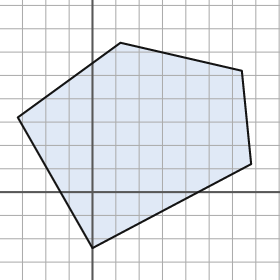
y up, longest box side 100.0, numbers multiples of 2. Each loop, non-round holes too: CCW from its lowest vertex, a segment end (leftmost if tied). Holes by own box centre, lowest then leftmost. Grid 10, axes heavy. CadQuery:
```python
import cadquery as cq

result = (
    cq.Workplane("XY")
    .moveTo(0.0, -24.0)
    .lineTo(68.0, 12.0)
    .lineTo(64.0, 52.0)
    .lineTo(12.0, 64.0)
    .lineTo(-32.0, 32.0)
    .close()
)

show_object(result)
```